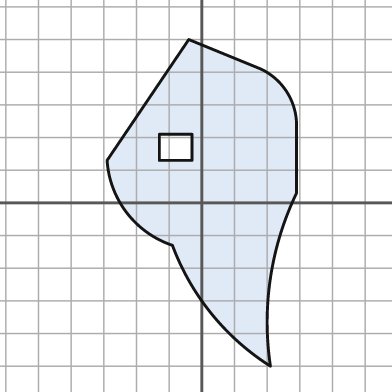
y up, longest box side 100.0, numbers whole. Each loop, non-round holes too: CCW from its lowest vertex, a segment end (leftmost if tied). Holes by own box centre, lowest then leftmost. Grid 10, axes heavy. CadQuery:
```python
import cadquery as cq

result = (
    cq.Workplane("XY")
    .moveTo(21.0, -50.0)
    .threePointArc((21.0, -23.0), (29.0, 3.0))
    .lineTo(29.0, 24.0)
    .threePointArc((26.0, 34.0), (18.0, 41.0))
    .lineTo(-4.0, 50.0)
    .lineTo(-29.0, 13.0)
    .threePointArc((-23.0, -3.0), (-9.0, -13.0))
    .threePointArc((3.0, -34.0), (21.0, -50.0))
    .close()
    .moveTo(-13.0, 13.0)
    .lineTo(-3.0, 13.0)
    .lineTo(-3.0, 21.0)
    .lineTo(-13.0, 21.0)
    .close()
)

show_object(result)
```